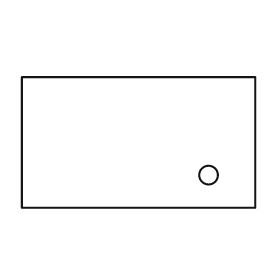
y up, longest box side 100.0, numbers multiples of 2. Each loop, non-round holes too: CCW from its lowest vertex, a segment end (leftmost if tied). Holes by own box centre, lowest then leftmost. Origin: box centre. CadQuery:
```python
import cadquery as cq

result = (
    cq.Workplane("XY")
    .moveTo(-50.0, -28.0)
    .lineTo(50.0, -28.0)
    .lineTo(50.0, 28.0)
    .lineTo(-50.0, 28.0)
    .close()
    .moveTo(30.0, -14.0)
    .circle(4.0)
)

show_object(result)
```